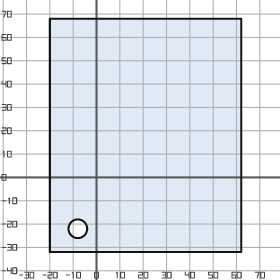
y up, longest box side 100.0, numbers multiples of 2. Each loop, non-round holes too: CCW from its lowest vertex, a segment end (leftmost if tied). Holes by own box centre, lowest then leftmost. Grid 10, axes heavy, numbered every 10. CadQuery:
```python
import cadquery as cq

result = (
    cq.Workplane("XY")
    .moveTo(-20.0, -32.0)
    .lineTo(62.0, -32.0)
    .lineTo(62.0, 68.0)
    .lineTo(-20.0, 68.0)
    .close()
    .moveTo(-8.0, -22.0)
    .circle(4.0)
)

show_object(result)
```